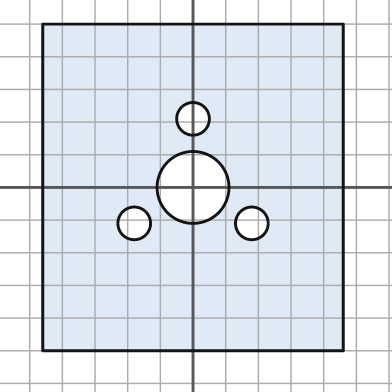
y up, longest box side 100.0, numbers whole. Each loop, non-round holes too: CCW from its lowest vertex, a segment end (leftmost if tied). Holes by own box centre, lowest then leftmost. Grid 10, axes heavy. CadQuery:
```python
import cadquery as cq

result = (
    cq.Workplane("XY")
    .moveTo(-46.0, -50.0)
    .lineTo(46.0, -50.0)
    .lineTo(46.0, 50.0)
    .lineTo(-46.0, 50.0)
    .close()
    .moveTo(-18.0, -11.0)
    .circle(5.0)
    .moveTo(18.0, -11.0)
    .circle(5.0)
    .moveTo(0.0, 0.0)
    .circle(11.0)
    .moveTo(0.0, 21.0)
    .circle(5.0)
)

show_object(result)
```